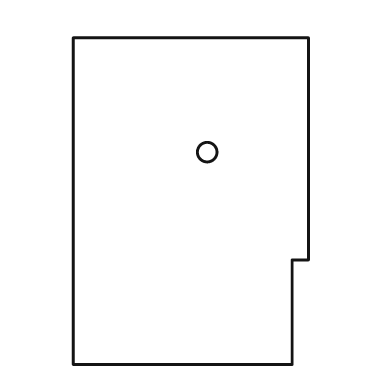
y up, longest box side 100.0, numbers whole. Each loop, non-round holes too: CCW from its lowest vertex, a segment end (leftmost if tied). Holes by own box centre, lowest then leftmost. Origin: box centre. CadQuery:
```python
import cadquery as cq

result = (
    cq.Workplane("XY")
    .moveTo(-36.0, -50.0)
    .lineTo(31.0, -50.0)
    .lineTo(31.0, -18.0)
    .lineTo(36.0, -18.0)
    .lineTo(36.0, 50.0)
    .lineTo(-36.0, 50.0)
    .close()
    .moveTo(5.0, 15.0)
    .circle(3.0)
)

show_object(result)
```